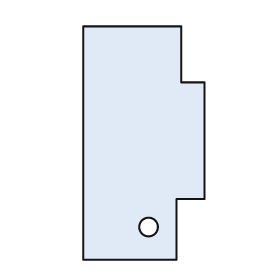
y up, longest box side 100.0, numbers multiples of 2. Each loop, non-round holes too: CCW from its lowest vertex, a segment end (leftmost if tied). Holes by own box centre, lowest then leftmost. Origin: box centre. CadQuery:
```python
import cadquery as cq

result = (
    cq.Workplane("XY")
    .moveTo(-26.0, -50.0)
    .lineTo(14.0, -50.0)
    .lineTo(14.0, -24.0)
    .lineTo(26.0, -24.0)
    .lineTo(26.0, 26.0)
    .lineTo(16.0, 26.0)
    .lineTo(16.0, 50.0)
    .lineTo(-26.0, 50.0)
    .close()
    .moveTo(2.0, -36.0)
    .circle(4.0)
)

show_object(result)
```